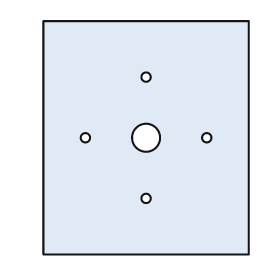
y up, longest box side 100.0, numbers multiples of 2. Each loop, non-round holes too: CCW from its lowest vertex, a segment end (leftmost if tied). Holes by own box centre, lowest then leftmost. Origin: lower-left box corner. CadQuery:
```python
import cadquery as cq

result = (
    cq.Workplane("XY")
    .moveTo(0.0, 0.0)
    .lineTo(88.0, 0.0)
    .lineTo(88.0, 100.0)
    .lineTo(0.0, 100.0)
    .close()
    .moveTo(44.0, 24.0)
    .circle(2.0)
    .moveTo(18.0, 50.0)
    .circle(2.0)
    .moveTo(44.0, 50.0)
    .circle(6.0)
    .moveTo(70.0, 50.0)
    .circle(2.0)
    .moveTo(44.0, 76.0)
    .circle(2.0)
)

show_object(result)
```